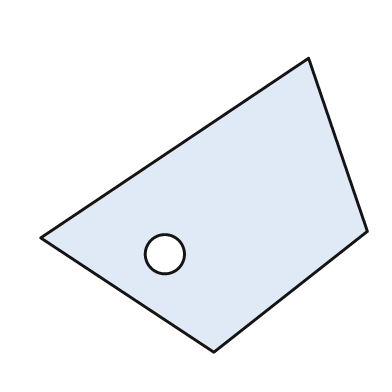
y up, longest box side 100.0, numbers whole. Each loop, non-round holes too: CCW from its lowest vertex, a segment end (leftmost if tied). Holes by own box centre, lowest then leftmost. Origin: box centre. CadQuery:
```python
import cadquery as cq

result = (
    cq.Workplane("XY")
    .moveTo(3.0, -45.0)
    .lineTo(50.0, -8.0)
    .lineTo(32.0, 45.0)
    .lineTo(-50.0, -10.0)
    .close()
    .moveTo(-12.0, -15.0)
    .circle(6.0)
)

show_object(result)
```